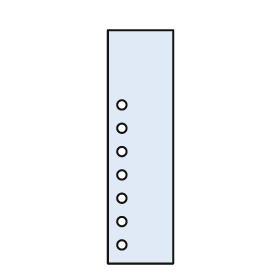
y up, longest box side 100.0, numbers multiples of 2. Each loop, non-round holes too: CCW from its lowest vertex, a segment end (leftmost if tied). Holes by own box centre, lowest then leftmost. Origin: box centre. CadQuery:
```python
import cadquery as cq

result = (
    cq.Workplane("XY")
    .moveTo(-14.0, -50.0)
    .lineTo(14.0, -50.0)
    .lineTo(14.0, 50.0)
    .lineTo(-14.0, 50.0)
    .close()
    .moveTo(-8.0, -42.0)
    .circle(2.0)
    .moveTo(-8.0, -32.0)
    .circle(2.0)
    .moveTo(-8.0, -22.0)
    .circle(2.0)
    .moveTo(-8.0, -12.0)
    .circle(2.0)
    .moveTo(-8.0, -2.0)
    .circle(2.0)
    .moveTo(-8.0, 8.0)
    .circle(2.0)
    .moveTo(-8.0, 18.0)
    .circle(2.0)
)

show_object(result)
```